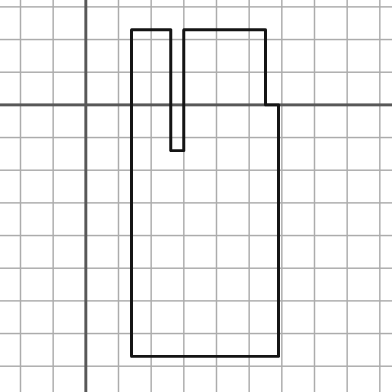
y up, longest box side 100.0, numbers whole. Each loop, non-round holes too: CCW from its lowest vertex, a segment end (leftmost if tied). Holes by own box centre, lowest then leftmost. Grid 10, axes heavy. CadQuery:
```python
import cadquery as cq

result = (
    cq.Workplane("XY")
    .moveTo(14.0, -77.0)
    .lineTo(59.0, -77.0)
    .lineTo(59.0, 0.0)
    .lineTo(55.0, 0.0)
    .lineTo(55.0, 23.0)
    .lineTo(30.0, 23.0)
    .lineTo(30.0, -14.0)
    .lineTo(26.0, -14.0)
    .lineTo(26.0, 23.0)
    .lineTo(14.0, 23.0)
    .close()
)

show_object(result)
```